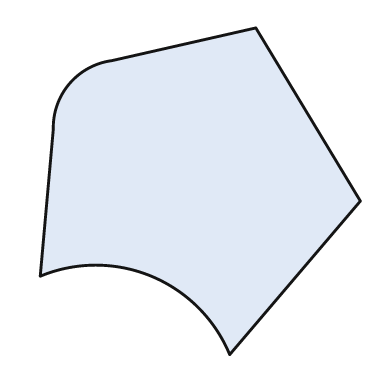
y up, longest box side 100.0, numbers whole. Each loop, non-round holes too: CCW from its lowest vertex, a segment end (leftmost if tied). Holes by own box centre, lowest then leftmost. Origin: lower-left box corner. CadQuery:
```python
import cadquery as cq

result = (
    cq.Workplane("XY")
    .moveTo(58.0, 0.0)
    .lineTo(98.0, 47.0)
    .lineTo(66.0, 100.0)
    .lineTo(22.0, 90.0)
    .threePointArc((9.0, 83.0), (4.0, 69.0))
    .lineTo(0.0, 24.0)
    .threePointArc((34.0, 24.0), (58.0, 0.0))
    .close()
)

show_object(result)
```